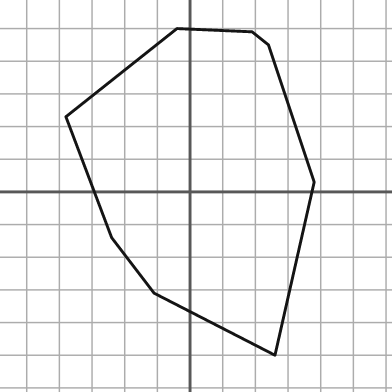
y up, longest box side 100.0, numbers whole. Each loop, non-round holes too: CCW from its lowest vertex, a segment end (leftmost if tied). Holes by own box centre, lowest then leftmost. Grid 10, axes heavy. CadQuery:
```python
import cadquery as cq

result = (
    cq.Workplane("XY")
    .moveTo(26.0, -50.0)
    .lineTo(38.0, 3.0)
    .lineTo(24.0, 45.0)
    .lineTo(19.0, 49.0)
    .lineTo(-4.0, 50.0)
    .lineTo(-38.0, 23.0)
    .lineTo(-24.0, -14.0)
    .lineTo(-11.0, -31.0)
    .close()
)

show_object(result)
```